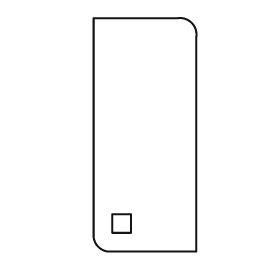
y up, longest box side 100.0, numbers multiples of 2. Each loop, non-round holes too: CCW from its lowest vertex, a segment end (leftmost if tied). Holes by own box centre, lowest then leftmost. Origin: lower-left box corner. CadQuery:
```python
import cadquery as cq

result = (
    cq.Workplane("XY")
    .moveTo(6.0, 0.0)
    .lineTo(44.0, 0.0)
    .lineTo(44.0, 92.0)
    .threePointArc((42.0, 98.0), (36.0, 100.0))
    .lineTo(0.0, 100.0)
    .lineTo(0.0, 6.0)
    .threePointArc((2.0, 2.0), (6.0, 0.0))
    .close()
    .moveTo(8.0, 8.0)
    .lineTo(16.0, 8.0)
    .lineTo(16.0, 16.0)
    .lineTo(8.0, 16.0)
    .close()
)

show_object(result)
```